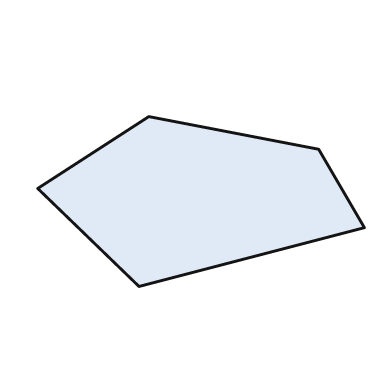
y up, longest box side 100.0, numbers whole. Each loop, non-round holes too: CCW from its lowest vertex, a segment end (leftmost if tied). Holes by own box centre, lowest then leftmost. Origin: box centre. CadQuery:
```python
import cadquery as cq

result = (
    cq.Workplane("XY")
    .moveTo(-19.0, -26.0)
    .lineTo(50.0, -8.0)
    .lineTo(36.0, 16.0)
    .lineTo(-16.0, 26.0)
    .lineTo(-50.0, 4.0)
    .close()
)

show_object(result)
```